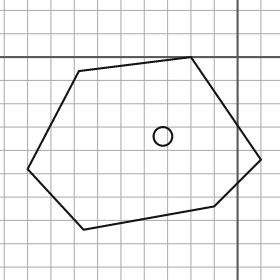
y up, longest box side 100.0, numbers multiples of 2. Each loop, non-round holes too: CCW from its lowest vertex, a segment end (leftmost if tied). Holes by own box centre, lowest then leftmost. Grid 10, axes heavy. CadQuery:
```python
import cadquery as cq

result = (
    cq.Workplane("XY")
    .moveTo(-66.0, -74.0)
    .lineTo(-10.0, -64.0)
    .lineTo(10.0, -44.0)
    .lineTo(-20.0, 0.0)
    .lineTo(-68.0, -6.0)
    .lineTo(-90.0, -48.0)
    .close()
    .moveTo(-32.0, -34.0)
    .circle(4.0)
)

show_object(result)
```